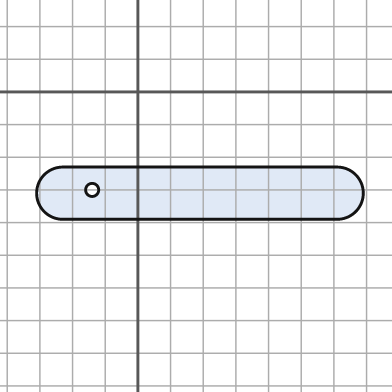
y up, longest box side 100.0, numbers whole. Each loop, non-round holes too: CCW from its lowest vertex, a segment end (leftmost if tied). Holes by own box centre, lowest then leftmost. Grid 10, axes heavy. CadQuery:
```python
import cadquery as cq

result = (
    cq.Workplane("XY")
    .moveTo(-23.0, -39.0)
    .lineTo(61.0, -39.0)
    .threePointArc((69.0, -31.0), (61.0, -23.0))
    .lineTo(-23.0, -23.0)
    .threePointArc((-31.0, -31.0), (-23.0, -39.0))
    .close()
    .moveTo(-14.0, -30.0)
    .circle(2.0)
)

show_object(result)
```